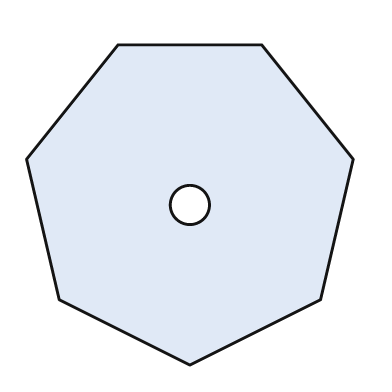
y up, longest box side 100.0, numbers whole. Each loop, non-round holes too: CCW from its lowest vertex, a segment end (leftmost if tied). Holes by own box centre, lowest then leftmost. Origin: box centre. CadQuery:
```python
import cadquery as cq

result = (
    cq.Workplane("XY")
    .moveTo(0.0, -49.0)
    .lineTo(40.0, -29.0)
    .lineTo(50.0, 14.0)
    .lineTo(22.0, 49.0)
    .lineTo(-22.0, 49.0)
    .lineTo(-50.0, 14.0)
    .lineTo(-40.0, -29.0)
    .close()
    .moveTo(0.0, 0.0)
    .circle(6.0)
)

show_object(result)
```